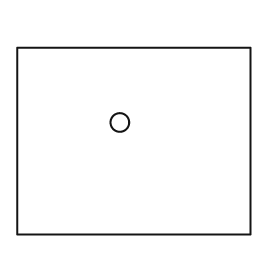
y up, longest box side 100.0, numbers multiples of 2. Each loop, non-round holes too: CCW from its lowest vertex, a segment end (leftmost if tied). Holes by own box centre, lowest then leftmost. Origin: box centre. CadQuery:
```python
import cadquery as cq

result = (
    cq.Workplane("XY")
    .moveTo(-50.0, -40.0)
    .lineTo(50.0, -40.0)
    .lineTo(50.0, 40.0)
    .lineTo(-50.0, 40.0)
    .close()
    .moveTo(-6.0, 8.0)
    .circle(4.0)
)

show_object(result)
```